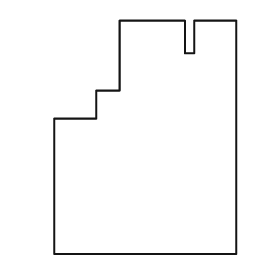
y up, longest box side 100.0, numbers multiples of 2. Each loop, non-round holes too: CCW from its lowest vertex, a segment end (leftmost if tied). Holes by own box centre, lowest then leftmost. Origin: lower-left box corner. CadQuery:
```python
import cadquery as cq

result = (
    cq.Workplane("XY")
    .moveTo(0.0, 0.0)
    .lineTo(78.0, 0.0)
    .lineTo(78.0, 100.0)
    .lineTo(60.0, 100.0)
    .lineTo(60.0, 86.0)
    .lineTo(56.0, 86.0)
    .lineTo(56.0, 100.0)
    .lineTo(28.0, 100.0)
    .lineTo(28.0, 70.0)
    .lineTo(18.0, 70.0)
    .lineTo(18.0, 58.0)
    .lineTo(0.0, 58.0)
    .close()
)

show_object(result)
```